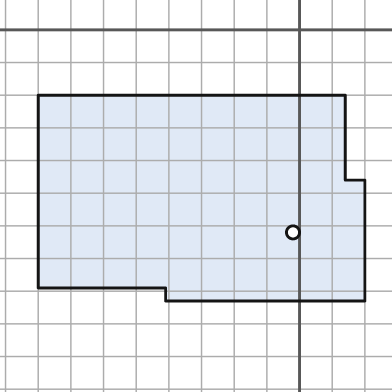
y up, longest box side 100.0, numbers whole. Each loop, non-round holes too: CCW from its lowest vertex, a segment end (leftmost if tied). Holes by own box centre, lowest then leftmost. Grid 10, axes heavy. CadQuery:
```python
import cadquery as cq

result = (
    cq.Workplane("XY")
    .moveTo(-41.0, -83.0)
    .lineTo(20.0, -83.0)
    .lineTo(20.0, -46.0)
    .lineTo(14.0, -46.0)
    .lineTo(14.0, -20.0)
    .lineTo(-80.0, -20.0)
    .lineTo(-80.0, -79.0)
    .lineTo(-41.0, -79.0)
    .close()
    .moveTo(-2.0, -62.0)
    .circle(2.0)
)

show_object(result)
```